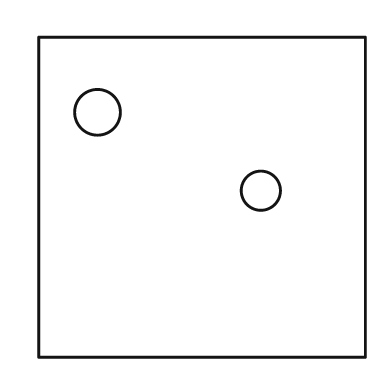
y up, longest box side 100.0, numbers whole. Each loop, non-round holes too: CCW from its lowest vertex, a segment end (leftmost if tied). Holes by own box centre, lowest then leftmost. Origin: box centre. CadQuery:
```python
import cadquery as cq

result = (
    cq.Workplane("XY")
    .moveTo(-50.0, -49.0)
    .lineTo(50.0, -49.0)
    .lineTo(50.0, 49.0)
    .lineTo(-50.0, 49.0)
    .close()
    .moveTo(18.0, 2.0)
    .circle(6.0)
    .moveTo(-32.0, 26.0)
    .circle(7.0)
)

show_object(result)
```